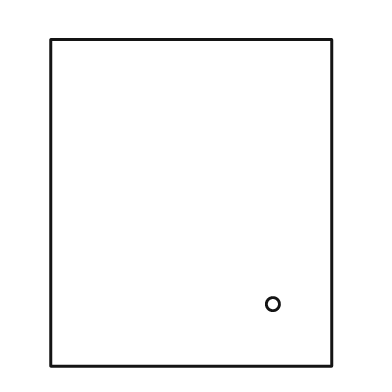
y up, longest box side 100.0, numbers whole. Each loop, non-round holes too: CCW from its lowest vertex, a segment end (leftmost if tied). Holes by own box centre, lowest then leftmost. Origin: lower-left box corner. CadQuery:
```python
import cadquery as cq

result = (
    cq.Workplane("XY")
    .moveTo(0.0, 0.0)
    .lineTo(86.0, 0.0)
    .lineTo(86.0, 100.0)
    .lineTo(0.0, 100.0)
    .close()
    .moveTo(68.0, 19.0)
    .circle(2.0)
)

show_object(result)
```